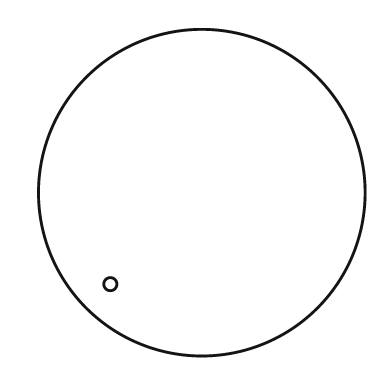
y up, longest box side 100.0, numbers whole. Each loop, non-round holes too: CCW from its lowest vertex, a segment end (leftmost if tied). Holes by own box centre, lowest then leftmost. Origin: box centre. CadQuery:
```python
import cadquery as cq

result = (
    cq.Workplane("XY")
    .moveTo(0.0, 0.0)
    .circle(50.0)
    .moveTo(-28.0, -28.0)
    .circle(2.0)
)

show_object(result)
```